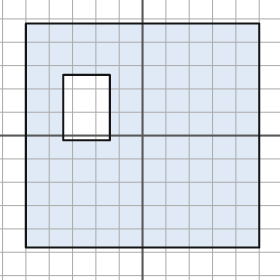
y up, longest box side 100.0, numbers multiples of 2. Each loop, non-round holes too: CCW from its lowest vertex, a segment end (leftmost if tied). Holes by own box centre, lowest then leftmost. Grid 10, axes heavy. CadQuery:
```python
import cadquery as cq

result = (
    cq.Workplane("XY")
    .moveTo(-50.0, -48.0)
    .lineTo(50.0, -48.0)
    .lineTo(50.0, 48.0)
    .lineTo(-50.0, 48.0)
    .close()
    .moveTo(-34.0, -2.0)
    .lineTo(-14.0, -2.0)
    .lineTo(-14.0, 26.0)
    .lineTo(-34.0, 26.0)
    .close()
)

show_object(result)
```